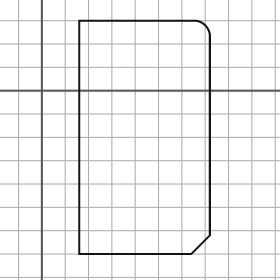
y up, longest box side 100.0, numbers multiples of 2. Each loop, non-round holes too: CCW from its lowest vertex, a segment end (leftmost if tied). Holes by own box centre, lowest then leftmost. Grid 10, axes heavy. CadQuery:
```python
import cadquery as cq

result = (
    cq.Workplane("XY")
    .moveTo(16.0, -70.0)
    .lineTo(64.0, -70.0)
    .lineTo(72.0, -62.0)
    .lineTo(72.0, 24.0)
    .threePointArc((70.0, 28.0), (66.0, 30.0))
    .lineTo(16.0, 30.0)
    .close()
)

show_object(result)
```